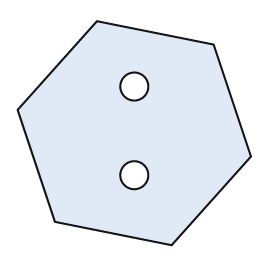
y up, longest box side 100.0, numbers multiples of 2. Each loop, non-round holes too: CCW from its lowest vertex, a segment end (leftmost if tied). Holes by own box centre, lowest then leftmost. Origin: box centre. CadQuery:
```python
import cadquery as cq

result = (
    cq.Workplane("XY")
    .moveTo(16.0, -48.0)
    .lineTo(50.0, -10.0)
    .lineTo(34.0, 38.0)
    .lineTo(-16.0, 48.0)
    .lineTo(-50.0, 10.0)
    .lineTo(-34.0, -38.0)
    .close()
    .moveTo(0.0, -18.0)
    .circle(6.0)
    .moveTo(0.0, 20.0)
    .circle(6.0)
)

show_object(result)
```